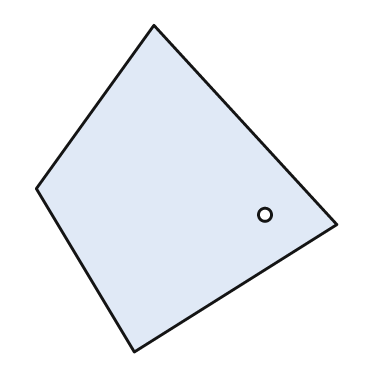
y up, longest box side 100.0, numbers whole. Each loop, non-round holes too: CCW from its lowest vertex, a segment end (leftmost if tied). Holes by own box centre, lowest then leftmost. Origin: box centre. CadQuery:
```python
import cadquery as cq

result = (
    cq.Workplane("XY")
    .moveTo(-16.0, -50.0)
    .lineTo(46.0, -11.0)
    .lineTo(-10.0, 50.0)
    .lineTo(-46.0, 0.0)
    .close()
    .moveTo(24.0, -8.0)
    .circle(2.0)
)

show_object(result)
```